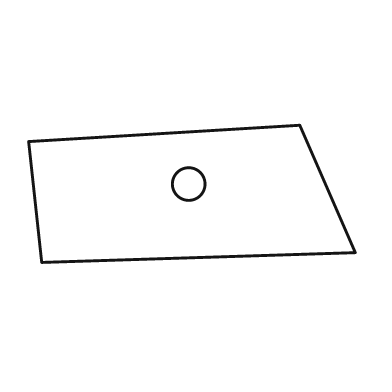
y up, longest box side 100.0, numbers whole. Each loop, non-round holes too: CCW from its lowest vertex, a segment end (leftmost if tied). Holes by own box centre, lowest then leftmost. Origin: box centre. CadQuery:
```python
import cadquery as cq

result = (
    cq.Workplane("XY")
    .moveTo(-46.0, -21.0)
    .lineTo(50.0, -18.0)
    .lineTo(33.0, 21.0)
    .lineTo(-50.0, 16.0)
    .close()
    .moveTo(-1.0, 3.0)
    .circle(5.0)
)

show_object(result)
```